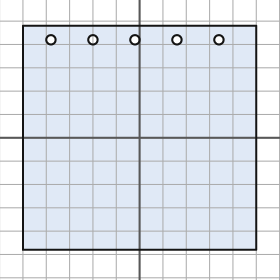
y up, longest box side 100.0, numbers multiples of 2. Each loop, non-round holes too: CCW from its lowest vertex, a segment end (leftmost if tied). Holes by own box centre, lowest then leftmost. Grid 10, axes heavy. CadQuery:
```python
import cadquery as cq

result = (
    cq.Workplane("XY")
    .moveTo(-50.0, -48.0)
    .lineTo(50.0, -48.0)
    .lineTo(50.0, 48.0)
    .lineTo(-50.0, 48.0)
    .close()
    .moveTo(-38.0, 42.0)
    .circle(2.0)
    .moveTo(-20.0, 42.0)
    .circle(2.0)
    .moveTo(-2.0, 42.0)
    .circle(2.0)
    .moveTo(16.0, 42.0)
    .circle(2.0)
    .moveTo(34.0, 42.0)
    .circle(2.0)
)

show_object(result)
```